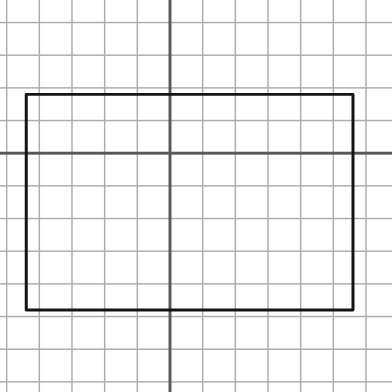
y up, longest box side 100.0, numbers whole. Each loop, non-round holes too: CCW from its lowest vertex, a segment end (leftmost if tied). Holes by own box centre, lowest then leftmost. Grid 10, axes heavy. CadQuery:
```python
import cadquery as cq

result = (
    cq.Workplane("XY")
    .moveTo(-44.0, -48.0)
    .lineTo(56.0, -48.0)
    .lineTo(56.0, 18.0)
    .lineTo(-44.0, 18.0)
    .close()
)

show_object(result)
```